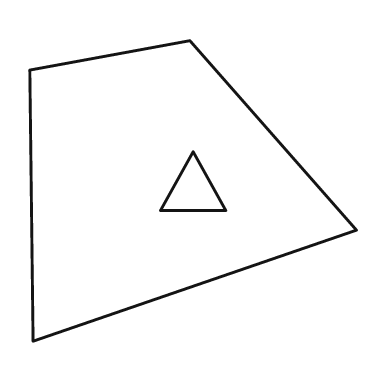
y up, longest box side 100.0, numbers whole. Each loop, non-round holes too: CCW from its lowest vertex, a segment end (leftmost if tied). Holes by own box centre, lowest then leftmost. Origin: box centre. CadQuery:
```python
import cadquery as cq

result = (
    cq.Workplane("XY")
    .moveTo(-49.0, -46.0)
    .lineTo(50.0, -12.0)
    .lineTo(-1.0, 46.0)
    .lineTo(-50.0, 37.0)
    .close()
    .moveTo(-10.0, -6.0)
    .lineTo(10.0, -6.0)
    .lineTo(0.0, 12.0)
    .close()
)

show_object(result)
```